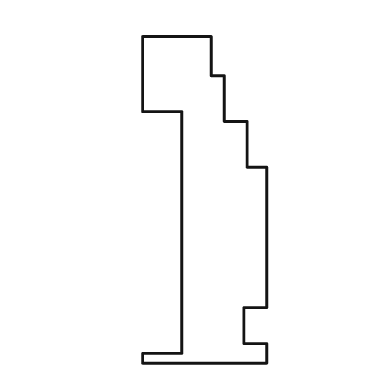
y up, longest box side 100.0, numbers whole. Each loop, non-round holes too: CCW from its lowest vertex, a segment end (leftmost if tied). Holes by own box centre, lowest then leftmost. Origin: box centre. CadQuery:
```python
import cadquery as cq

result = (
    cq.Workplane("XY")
    .moveTo(-19.0, -50.0)
    .lineTo(19.0, -50.0)
    .lineTo(19.0, -44.0)
    .lineTo(12.0, -44.0)
    .lineTo(12.0, -33.0)
    .lineTo(19.0, -33.0)
    .lineTo(19.0, 10.0)
    .lineTo(13.0, 10.0)
    .lineTo(13.0, 24.0)
    .lineTo(6.0, 24.0)
    .lineTo(6.0, 38.0)
    .lineTo(2.0, 38.0)
    .lineTo(2.0, 50.0)
    .lineTo(-19.0, 50.0)
    .lineTo(-19.0, 27.0)
    .lineTo(-7.0, 27.0)
    .lineTo(-7.0, -47.0)
    .lineTo(-19.0, -47.0)
    .close()
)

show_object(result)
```